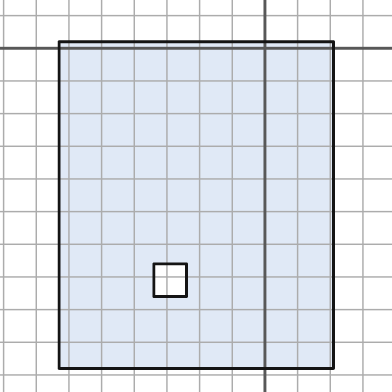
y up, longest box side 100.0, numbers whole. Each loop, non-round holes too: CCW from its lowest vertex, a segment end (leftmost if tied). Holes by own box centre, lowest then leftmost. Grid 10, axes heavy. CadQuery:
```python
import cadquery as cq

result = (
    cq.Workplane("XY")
    .moveTo(-63.0, -98.0)
    .lineTo(21.0, -98.0)
    .lineTo(21.0, 2.0)
    .lineTo(-63.0, 2.0)
    .close()
    .moveTo(-34.0, -76.0)
    .lineTo(-24.0, -76.0)
    .lineTo(-24.0, -66.0)
    .lineTo(-34.0, -66.0)
    .close()
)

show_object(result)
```